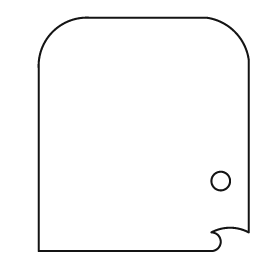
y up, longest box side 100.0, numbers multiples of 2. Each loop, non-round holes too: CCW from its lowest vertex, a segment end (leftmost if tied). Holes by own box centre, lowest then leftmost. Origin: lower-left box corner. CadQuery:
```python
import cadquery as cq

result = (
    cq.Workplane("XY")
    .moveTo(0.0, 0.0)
    .lineTo(74.0, 0.0)
    .threePointArc((78.0, 4.0), (74.0, 8.0))
    .threePointArc((82.0, 10.0), (90.0, 8.0))
    .lineTo(90.0, 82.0)
    .threePointArc((84.0, 94.0), (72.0, 100.0))
    .lineTo(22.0, 100.0)
    .threePointArc((6.0, 94.0), (0.0, 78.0))
    .close()
    .moveTo(78.0, 30.0)
    .circle(4.0)
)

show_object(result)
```